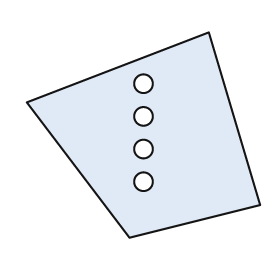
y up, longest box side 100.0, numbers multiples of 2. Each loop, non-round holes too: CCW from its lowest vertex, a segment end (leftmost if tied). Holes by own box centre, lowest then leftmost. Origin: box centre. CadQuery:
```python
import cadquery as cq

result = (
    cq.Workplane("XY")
    .moveTo(-6.0, -44.0)
    .lineTo(50.0, -30.0)
    .lineTo(28.0, 44.0)
    .lineTo(-50.0, 14.0)
    .close()
    .moveTo(0.0, -20.0)
    .circle(4.0)
    .moveTo(0.0, -6.0)
    .circle(4.0)
    .moveTo(0.0, 8.0)
    .circle(4.0)
    .moveTo(0.0, 22.0)
    .circle(4.0)
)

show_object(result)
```